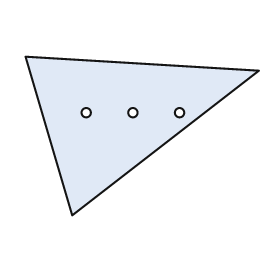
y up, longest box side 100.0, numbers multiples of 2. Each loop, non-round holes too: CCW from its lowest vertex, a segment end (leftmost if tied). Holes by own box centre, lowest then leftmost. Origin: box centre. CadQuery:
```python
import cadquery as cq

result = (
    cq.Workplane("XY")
    .moveTo(-30.0, -34.0)
    .lineTo(50.0, 28.0)
    .lineTo(-50.0, 34.0)
    .close()
    .moveTo(-24.0, 10.0)
    .circle(2.0)
    .moveTo(-4.0, 10.0)
    .circle(2.0)
    .moveTo(16.0, 10.0)
    .circle(2.0)
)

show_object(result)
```